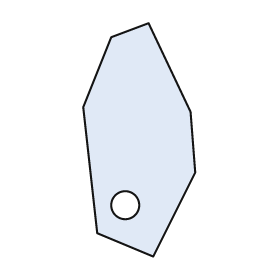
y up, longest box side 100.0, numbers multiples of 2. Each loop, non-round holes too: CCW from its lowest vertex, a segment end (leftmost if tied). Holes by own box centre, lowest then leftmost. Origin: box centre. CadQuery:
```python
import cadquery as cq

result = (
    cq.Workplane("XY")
    .moveTo(6.0, -50.0)
    .lineTo(24.0, -14.0)
    .lineTo(22.0, 12.0)
    .lineTo(4.0, 50.0)
    .lineTo(-12.0, 44.0)
    .lineTo(-24.0, 14.0)
    .lineTo(-18.0, -40.0)
    .close()
    .moveTo(-6.0, -28.0)
    .circle(6.0)
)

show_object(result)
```